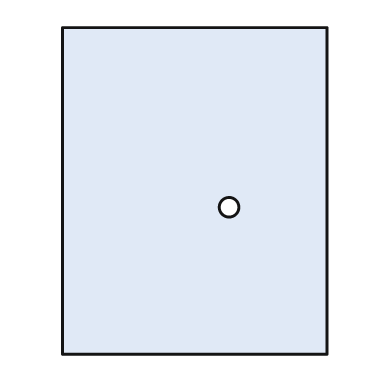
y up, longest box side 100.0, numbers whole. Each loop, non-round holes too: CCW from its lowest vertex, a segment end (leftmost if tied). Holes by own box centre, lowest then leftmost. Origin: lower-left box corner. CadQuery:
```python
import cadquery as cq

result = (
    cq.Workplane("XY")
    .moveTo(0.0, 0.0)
    .lineTo(81.0, 0.0)
    .lineTo(81.0, 100.0)
    .lineTo(0.0, 100.0)
    .close()
    .moveTo(51.0, 45.0)
    .circle(3.0)
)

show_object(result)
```